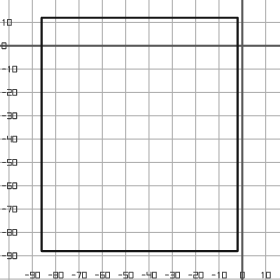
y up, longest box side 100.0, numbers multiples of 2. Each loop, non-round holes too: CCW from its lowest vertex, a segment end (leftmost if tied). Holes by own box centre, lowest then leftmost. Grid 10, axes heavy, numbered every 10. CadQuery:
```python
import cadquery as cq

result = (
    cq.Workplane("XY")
    .moveTo(-86.0, -88.0)
    .lineTo(-2.0, -88.0)
    .lineTo(-2.0, 12.0)
    .lineTo(-86.0, 12.0)
    .close()
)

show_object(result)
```